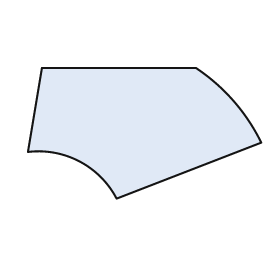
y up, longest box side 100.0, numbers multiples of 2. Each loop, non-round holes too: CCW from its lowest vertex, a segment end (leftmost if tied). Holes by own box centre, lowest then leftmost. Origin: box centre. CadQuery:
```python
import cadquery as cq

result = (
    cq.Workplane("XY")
    .moveTo(-12.0, -28.0)
    .lineTo(50.0, -4.0)
    .threePointArc((38.0, 14.0), (22.0, 28.0))
    .lineTo(-44.0, 28.0)
    .lineTo(-50.0, -8.0)
    .threePointArc((-28.0, -12.0), (-12.0, -28.0))
    .close()
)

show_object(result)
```